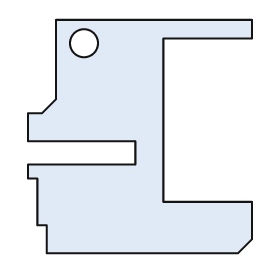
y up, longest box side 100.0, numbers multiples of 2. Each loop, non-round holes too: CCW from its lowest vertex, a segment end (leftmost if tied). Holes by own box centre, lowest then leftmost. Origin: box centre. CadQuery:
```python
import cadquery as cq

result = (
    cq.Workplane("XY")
    .moveTo(-40.0, -50.0)
    .lineTo(42.0, -50.0)
    .lineTo(48.0, -44.0)
    .lineTo(48.0, -28.0)
    .lineTo(10.0, -28.0)
    .lineTo(10.0, 42.0)
    .lineTo(48.0, 42.0)
    .lineTo(48.0, 50.0)
    .lineTo(-36.0, 50.0)
    .lineTo(-36.0, 16.0)
    .lineTo(-42.0, 10.0)
    .lineTo(-48.0, 10.0)
    .lineTo(-48.0, -2.0)
    .lineTo(-2.0, -2.0)
    .lineTo(-2.0, -12.0)
    .lineTo(-48.0, -12.0)
    .lineTo(-48.0, -18.0)
    .lineTo(-44.0, -18.0)
    .lineTo(-44.0, -38.0)
    .lineTo(-40.0, -38.0)
    .close()
    .moveTo(-24.0, 40.0)
    .circle(6.0)
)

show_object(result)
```